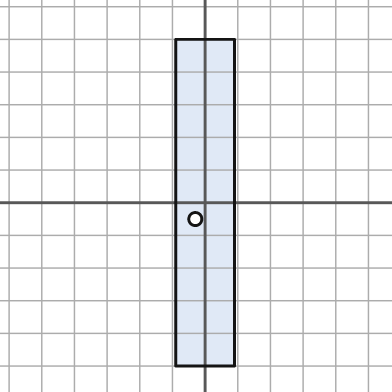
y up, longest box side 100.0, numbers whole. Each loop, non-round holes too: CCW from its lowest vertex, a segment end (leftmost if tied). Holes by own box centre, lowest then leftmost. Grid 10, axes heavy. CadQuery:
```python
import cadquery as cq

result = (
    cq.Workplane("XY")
    .moveTo(-9.0, -50.0)
    .lineTo(9.0, -50.0)
    .lineTo(9.0, 50.0)
    .lineTo(-9.0, 50.0)
    .close()
    .moveTo(-3.0, -5.0)
    .circle(2.0)
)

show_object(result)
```